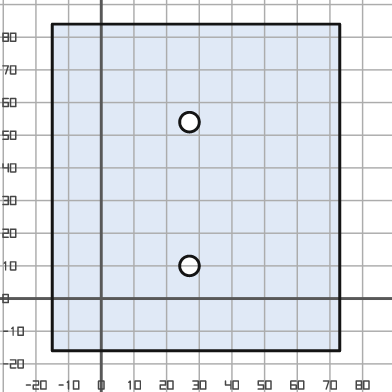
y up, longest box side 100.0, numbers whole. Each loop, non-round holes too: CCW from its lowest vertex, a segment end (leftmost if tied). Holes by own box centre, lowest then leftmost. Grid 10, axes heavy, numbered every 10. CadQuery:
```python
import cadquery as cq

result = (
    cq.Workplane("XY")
    .moveTo(-15.0, -16.0)
    .lineTo(73.0, -16.0)
    .lineTo(73.0, 84.0)
    .lineTo(-15.0, 84.0)
    .close()
    .moveTo(27.0, 10.0)
    .circle(3.0)
    .moveTo(27.0, 54.0)
    .circle(3.0)
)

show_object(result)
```